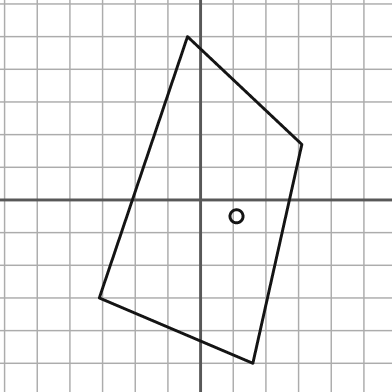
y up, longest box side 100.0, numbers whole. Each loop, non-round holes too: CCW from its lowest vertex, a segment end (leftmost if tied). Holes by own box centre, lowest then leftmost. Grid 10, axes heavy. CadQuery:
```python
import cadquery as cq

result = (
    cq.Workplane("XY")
    .moveTo(16.0, -50.0)
    .lineTo(31.0, 17.0)
    .lineTo(-4.0, 50.0)
    .lineTo(-31.0, -30.0)
    .close()
    .moveTo(11.0, -5.0)
    .circle(2.0)
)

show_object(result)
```